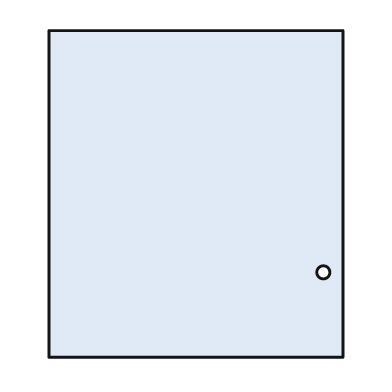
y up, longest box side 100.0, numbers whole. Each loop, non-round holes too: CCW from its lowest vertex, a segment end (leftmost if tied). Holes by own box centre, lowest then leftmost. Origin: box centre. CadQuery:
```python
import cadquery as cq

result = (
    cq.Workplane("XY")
    .moveTo(-45.0, -50.0)
    .lineTo(45.0, -50.0)
    .lineTo(45.0, 50.0)
    .lineTo(-45.0, 50.0)
    .close()
    .moveTo(39.0, -24.0)
    .circle(2.0)
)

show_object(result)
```